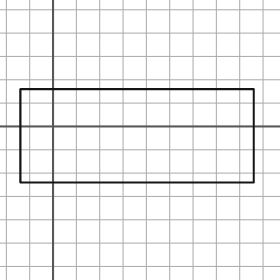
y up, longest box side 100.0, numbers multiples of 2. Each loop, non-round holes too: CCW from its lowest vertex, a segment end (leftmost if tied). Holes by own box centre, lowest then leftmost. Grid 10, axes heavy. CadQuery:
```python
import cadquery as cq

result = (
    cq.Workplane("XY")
    .moveTo(-14.0, -24.0)
    .lineTo(86.0, -24.0)
    .lineTo(86.0, 16.0)
    .lineTo(-14.0, 16.0)
    .close()
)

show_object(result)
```